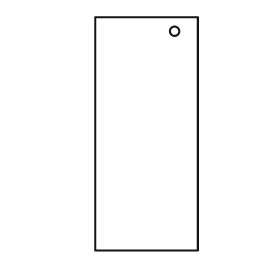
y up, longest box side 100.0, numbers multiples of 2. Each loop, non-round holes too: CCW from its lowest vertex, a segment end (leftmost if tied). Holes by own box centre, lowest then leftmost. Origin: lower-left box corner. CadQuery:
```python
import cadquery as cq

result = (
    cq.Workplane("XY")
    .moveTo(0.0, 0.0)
    .lineTo(44.0, 0.0)
    .lineTo(44.0, 100.0)
    .lineTo(0.0, 100.0)
    .close()
    .moveTo(34.0, 94.0)
    .circle(2.0)
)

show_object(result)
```